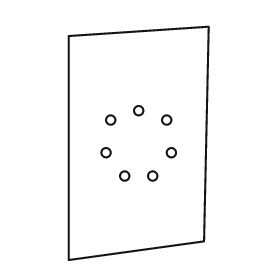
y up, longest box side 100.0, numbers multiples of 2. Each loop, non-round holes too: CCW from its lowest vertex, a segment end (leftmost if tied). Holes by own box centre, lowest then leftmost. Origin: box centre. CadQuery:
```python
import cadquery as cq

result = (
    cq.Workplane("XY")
    .moveTo(-30.0, -50.0)
    .lineTo(28.0, -42.0)
    .lineTo(30.0, 50.0)
    .lineTo(-30.0, 46.0)
    .close()
    .moveTo(-6.0, -14.0)
    .circle(2.0)
    .moveTo(6.0, -14.0)
    .circle(2.0)
    .moveTo(-14.0, -4.0)
    .circle(2.0)
    .moveTo(14.0, -4.0)
    .circle(2.0)
    .moveTo(-12.0, 10.0)
    .circle(2.0)
    .moveTo(12.0, 10.0)
    .circle(2.0)
    .moveTo(0.0, 14.0)
    .circle(2.0)
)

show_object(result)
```